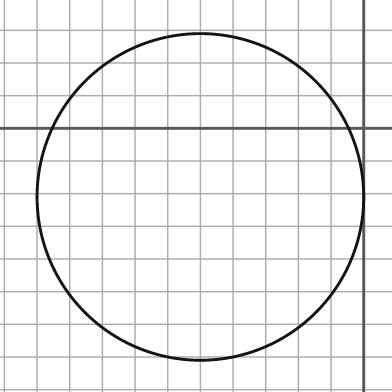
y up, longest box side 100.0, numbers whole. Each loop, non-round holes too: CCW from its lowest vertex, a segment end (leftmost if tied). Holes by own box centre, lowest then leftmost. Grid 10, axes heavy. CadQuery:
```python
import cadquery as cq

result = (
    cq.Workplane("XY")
    .moveTo(-50.0, -21.0)
    .circle(50.0)
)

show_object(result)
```